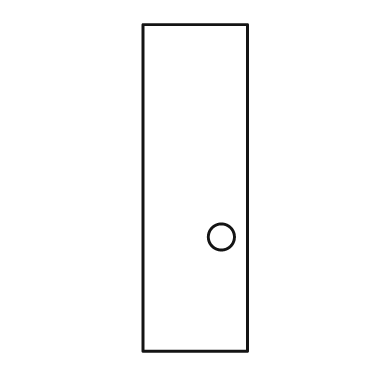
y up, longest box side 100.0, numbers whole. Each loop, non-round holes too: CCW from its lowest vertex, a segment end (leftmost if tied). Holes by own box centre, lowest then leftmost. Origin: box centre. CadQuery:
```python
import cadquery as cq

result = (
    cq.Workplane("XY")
    .moveTo(-16.0, -50.0)
    .lineTo(16.0, -50.0)
    .lineTo(16.0, 50.0)
    .lineTo(-16.0, 50.0)
    .close()
    .moveTo(8.0, -15.0)
    .circle(4.0)
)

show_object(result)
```